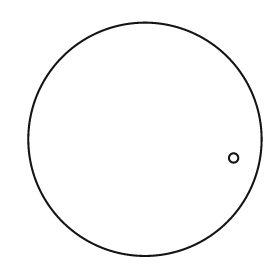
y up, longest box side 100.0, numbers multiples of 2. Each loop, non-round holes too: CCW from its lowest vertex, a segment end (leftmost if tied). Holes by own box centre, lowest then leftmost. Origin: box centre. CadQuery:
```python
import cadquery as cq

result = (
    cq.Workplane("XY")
    .moveTo(0.0, 0.0)
    .circle(50.0)
    .moveTo(38.0, -8.0)
    .circle(2.0)
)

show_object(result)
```